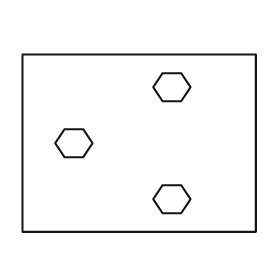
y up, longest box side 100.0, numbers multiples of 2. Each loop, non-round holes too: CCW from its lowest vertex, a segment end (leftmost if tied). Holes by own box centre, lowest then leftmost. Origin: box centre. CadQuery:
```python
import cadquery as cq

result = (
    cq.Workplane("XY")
    .moveTo(-50.0, -38.0)
    .lineTo(50.0, -38.0)
    .lineTo(50.0, 38.0)
    .lineTo(-50.0, 38.0)
    .close()
    .moveTo(10.0, -30.0)
    .lineTo(18.0, -30.0)
    .lineTo(22.0, -24.0)
    .lineTo(18.0, -18.0)
    .lineTo(10.0, -18.0)
    .lineTo(6.0, -24.0)
    .close()
    .moveTo(-32.0, -6.0)
    .lineTo(-24.0, -6.0)
    .lineTo(-20.0, 0.0)
    .lineTo(-24.0, 6.0)
    .lineTo(-32.0, 6.0)
    .lineTo(-36.0, 0.0)
    .close()
    .moveTo(10.0, 18.0)
    .lineTo(18.0, 18.0)
    .lineTo(22.0, 24.0)
    .lineTo(18.0, 30.0)
    .lineTo(10.0, 30.0)
    .lineTo(6.0, 24.0)
    .close()
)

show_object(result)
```